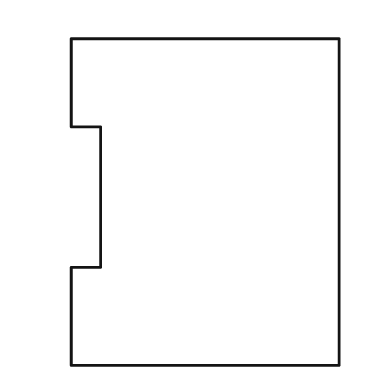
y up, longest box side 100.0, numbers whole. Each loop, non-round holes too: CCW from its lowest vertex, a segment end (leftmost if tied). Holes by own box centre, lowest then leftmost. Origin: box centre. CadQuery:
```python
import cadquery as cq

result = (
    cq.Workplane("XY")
    .moveTo(-41.0, -50.0)
    .lineTo(41.0, -50.0)
    .lineTo(41.0, 50.0)
    .lineTo(-41.0, 50.0)
    .lineTo(-41.0, 23.0)
    .lineTo(-32.0, 23.0)
    .lineTo(-32.0, -20.0)
    .lineTo(-41.0, -20.0)
    .close()
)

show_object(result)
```